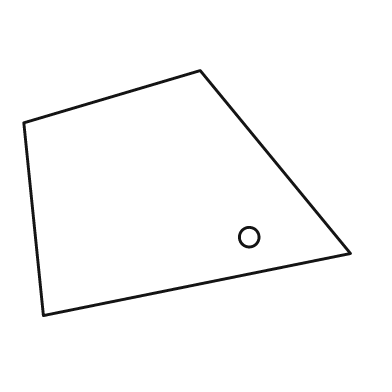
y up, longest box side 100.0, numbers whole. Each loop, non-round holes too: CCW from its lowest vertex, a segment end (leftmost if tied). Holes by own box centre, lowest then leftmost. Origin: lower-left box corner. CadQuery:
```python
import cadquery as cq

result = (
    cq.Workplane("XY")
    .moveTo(6.0, 0.0)
    .lineTo(100.0, 19.0)
    .lineTo(54.0, 75.0)
    .lineTo(0.0, 59.0)
    .close()
    .moveTo(69.0, 24.0)
    .circle(3.0)
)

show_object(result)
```